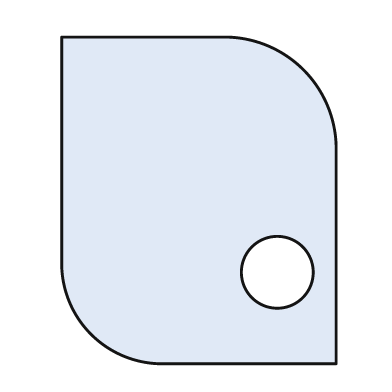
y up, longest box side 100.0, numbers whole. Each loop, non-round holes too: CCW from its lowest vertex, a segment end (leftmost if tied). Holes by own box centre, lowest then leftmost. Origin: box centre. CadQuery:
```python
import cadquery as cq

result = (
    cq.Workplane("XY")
    .moveTo(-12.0, -50.0)
    .lineTo(42.0, -50.0)
    .lineTo(42.0, 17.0)
    .threePointArc((32.0, 40.0), (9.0, 50.0))
    .lineTo(-42.0, 50.0)
    .lineTo(-42.0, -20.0)
    .threePointArc((-33.0, -41.0), (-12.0, -50.0))
    .close()
    .moveTo(24.0, -22.0)
    .circle(11.0)
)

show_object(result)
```